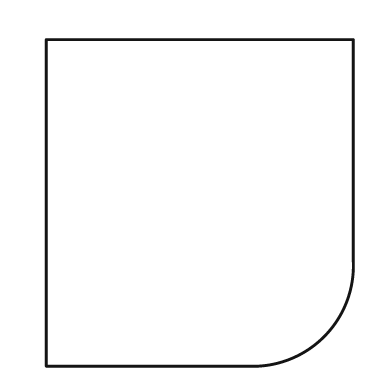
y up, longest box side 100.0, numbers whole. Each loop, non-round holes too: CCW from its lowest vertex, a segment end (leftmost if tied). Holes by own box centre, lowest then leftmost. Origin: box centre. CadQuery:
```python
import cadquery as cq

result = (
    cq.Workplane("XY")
    .moveTo(-47.0, -50.0)
    .lineTo(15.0, -50.0)
    .threePointArc((38.0, -41.0), (47.0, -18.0))
    .lineTo(47.0, 50.0)
    .lineTo(-47.0, 50.0)
    .close()
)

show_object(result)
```